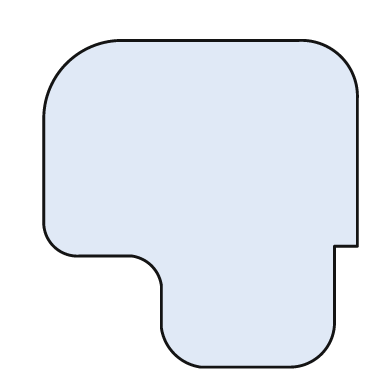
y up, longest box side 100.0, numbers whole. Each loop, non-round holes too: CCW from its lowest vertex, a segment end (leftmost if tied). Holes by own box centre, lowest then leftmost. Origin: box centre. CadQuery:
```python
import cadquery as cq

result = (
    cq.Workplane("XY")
    .moveTo(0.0, -50.0)
    .lineTo(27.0, -50.0)
    .threePointArc((37.0, -46.0), (41.0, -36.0))
    .lineTo(41.0, -13.0)
    .lineTo(48.0, -13.0)
    .lineTo(48.0, 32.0)
    .threePointArc((43.0, 45.0), (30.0, 50.0))
    .lineTo(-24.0, 50.0)
    .threePointArc((-41.0, 43.0), (-48.0, 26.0))
    .lineTo(-48.0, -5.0)
    .threePointArc((-45.0, -13.0), (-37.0, -16.0))
    .lineTo(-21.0, -16.0)
    .threePointArc((-15.0, -19.0), (-12.0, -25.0))
    .lineTo(-12.0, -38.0)
    .threePointArc((-8.0, -46.0), (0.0, -50.0))
    .close()
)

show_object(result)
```